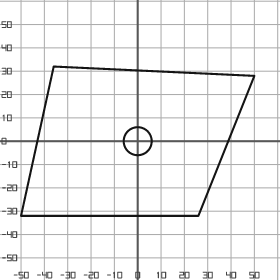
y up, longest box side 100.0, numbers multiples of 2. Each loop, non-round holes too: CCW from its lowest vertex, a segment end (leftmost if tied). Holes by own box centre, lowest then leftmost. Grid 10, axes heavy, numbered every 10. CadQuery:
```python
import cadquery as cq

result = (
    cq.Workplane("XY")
    .moveTo(-50.0, -32.0)
    .lineTo(26.0, -32.0)
    .lineTo(50.0, 28.0)
    .lineTo(-36.0, 32.0)
    .close()
    .moveTo(0.0, 0.0)
    .circle(6.0)
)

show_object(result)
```